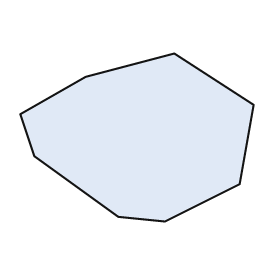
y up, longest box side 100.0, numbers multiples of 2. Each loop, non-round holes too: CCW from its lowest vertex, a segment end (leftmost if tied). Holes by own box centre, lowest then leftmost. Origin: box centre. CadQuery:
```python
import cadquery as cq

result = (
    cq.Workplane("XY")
    .moveTo(12.0, -36.0)
    .lineTo(44.0, -20.0)
    .lineTo(50.0, 14.0)
    .lineTo(16.0, 36.0)
    .lineTo(-22.0, 26.0)
    .lineTo(-50.0, 10.0)
    .lineTo(-44.0, -8.0)
    .lineTo(-8.0, -34.0)
    .close()
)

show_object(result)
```